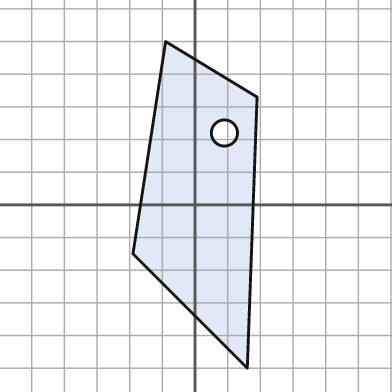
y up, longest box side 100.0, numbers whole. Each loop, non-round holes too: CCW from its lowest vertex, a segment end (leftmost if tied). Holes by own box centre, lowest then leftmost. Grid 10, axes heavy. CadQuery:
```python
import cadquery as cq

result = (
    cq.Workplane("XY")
    .moveTo(16.0, -50.0)
    .lineTo(19.0, 33.0)
    .lineTo(-9.0, 50.0)
    .lineTo(-19.0, -15.0)
    .close()
    .moveTo(9.0, 22.0)
    .circle(4.0)
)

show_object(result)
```